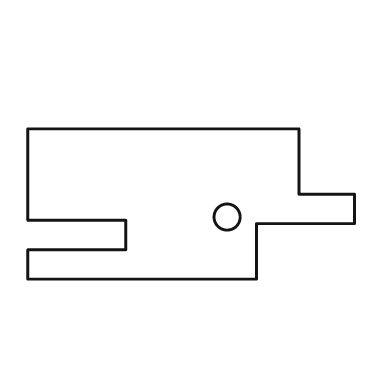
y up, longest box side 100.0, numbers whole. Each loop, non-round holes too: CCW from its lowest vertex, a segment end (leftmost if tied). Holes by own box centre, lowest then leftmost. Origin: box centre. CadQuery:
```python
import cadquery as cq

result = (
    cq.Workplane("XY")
    .moveTo(-50.0, -23.0)
    .lineTo(20.0, -23.0)
    .lineTo(20.0, -6.0)
    .lineTo(50.0, -6.0)
    .lineTo(50.0, 3.0)
    .lineTo(33.0, 3.0)
    .lineTo(33.0, 23.0)
    .lineTo(-50.0, 23.0)
    .lineTo(-50.0, -5.0)
    .lineTo(-20.0, -5.0)
    .lineTo(-20.0, -14.0)
    .lineTo(-50.0, -14.0)
    .close()
    .moveTo(11.0, -4.0)
    .circle(4.0)
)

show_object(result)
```